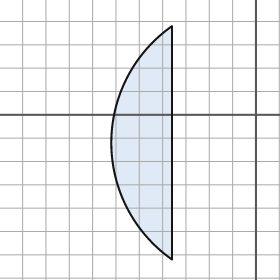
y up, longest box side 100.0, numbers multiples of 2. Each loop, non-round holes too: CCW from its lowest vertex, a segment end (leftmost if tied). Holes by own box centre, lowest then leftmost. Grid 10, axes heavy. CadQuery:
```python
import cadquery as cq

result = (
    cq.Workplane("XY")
    .moveTo(-36.0, -62.0)
    .lineTo(-36.0, 38.0)
    .threePointArc((-62.0, -12.0), (-36.0, -62.0))
    .close()
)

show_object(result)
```